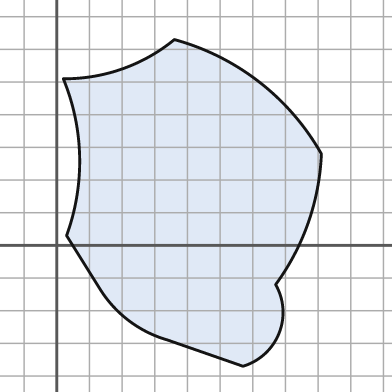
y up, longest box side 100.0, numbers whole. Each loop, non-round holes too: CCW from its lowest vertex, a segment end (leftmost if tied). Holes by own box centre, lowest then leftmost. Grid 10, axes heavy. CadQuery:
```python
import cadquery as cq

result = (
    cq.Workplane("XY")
    .moveTo(57.0, -37.0)
    .threePointArc((68.0, -27.0), (67.0, -12.0))
    .threePointArc((77.0, 7.0), (81.0, 28.0))
    .threePointArc((62.0, 50.0), (36.0, 63.0))
    .threePointArc((20.0, 54.0), (2.0, 51.0))
    .threePointArc((7.0, 27.0), (3.0, 3.0))
    .lineTo(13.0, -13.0)
    .threePointArc((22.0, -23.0), (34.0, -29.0))
    .close()
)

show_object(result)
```